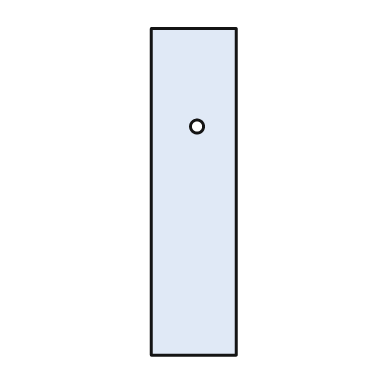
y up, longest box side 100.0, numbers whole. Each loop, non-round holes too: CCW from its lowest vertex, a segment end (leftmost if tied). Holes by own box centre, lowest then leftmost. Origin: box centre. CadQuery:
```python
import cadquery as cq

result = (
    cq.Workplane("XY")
    .moveTo(-13.0, -50.0)
    .lineTo(13.0, -50.0)
    .lineTo(13.0, 50.0)
    .lineTo(-13.0, 50.0)
    .close()
    .moveTo(1.0, 20.0)
    .circle(2.0)
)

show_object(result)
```